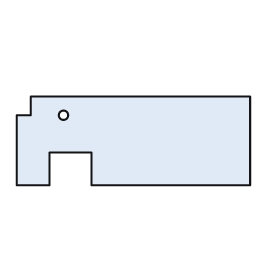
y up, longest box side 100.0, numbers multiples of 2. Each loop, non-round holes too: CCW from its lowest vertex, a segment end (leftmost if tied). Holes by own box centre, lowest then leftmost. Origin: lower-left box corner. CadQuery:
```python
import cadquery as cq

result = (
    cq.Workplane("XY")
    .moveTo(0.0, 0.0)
    .lineTo(14.0, 0.0)
    .lineTo(14.0, 14.0)
    .lineTo(32.0, 14.0)
    .lineTo(32.0, 0.0)
    .lineTo(100.0, 0.0)
    .lineTo(100.0, 38.0)
    .lineTo(6.0, 38.0)
    .lineTo(6.0, 30.0)
    .lineTo(0.0, 30.0)
    .close()
    .moveTo(20.0, 30.0)
    .circle(2.0)
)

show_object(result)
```